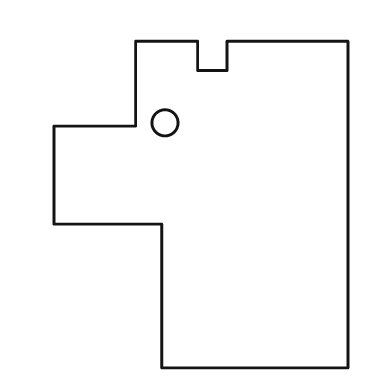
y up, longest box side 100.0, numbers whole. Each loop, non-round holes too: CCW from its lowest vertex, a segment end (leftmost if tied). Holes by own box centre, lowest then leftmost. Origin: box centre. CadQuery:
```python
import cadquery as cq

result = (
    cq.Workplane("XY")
    .moveTo(-12.0, -50.0)
    .lineTo(45.0, -50.0)
    .lineTo(45.0, 50.0)
    .lineTo(8.0, 50.0)
    .lineTo(8.0, 41.0)
    .lineTo(-1.0, 41.0)
    .lineTo(-1.0, 50.0)
    .lineTo(-20.0, 50.0)
    .lineTo(-20.0, 24.0)
    .lineTo(-45.0, 24.0)
    .lineTo(-45.0, -6.0)
    .lineTo(-12.0, -6.0)
    .close()
    .moveTo(-11.0, 25.0)
    .circle(4.0)
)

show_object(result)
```